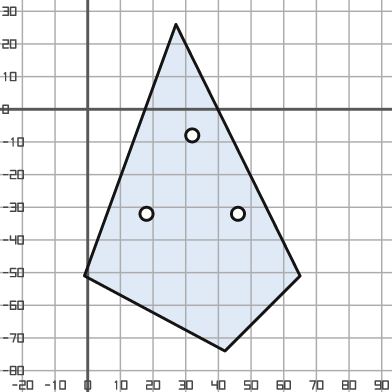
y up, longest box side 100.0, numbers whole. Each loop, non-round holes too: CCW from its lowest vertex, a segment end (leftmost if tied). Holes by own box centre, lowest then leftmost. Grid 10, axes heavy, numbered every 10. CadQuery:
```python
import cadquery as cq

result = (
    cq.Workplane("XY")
    .moveTo(42.0, -74.0)
    .lineTo(65.0, -51.0)
    .lineTo(27.0, 26.0)
    .lineTo(-1.0, -51.0)
    .close()
    .moveTo(18.0, -32.0)
    .circle(2.0)
    .moveTo(46.0, -32.0)
    .circle(2.0)
    .moveTo(32.0, -8.0)
    .circle(2.0)
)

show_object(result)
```